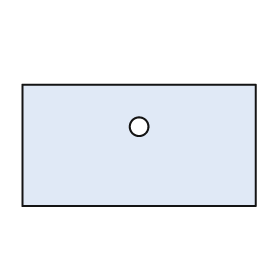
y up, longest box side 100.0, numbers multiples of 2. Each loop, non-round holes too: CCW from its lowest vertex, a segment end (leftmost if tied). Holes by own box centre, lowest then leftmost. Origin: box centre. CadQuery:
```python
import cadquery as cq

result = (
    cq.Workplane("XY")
    .moveTo(-50.0, -26.0)
    .lineTo(50.0, -26.0)
    .lineTo(50.0, 26.0)
    .lineTo(-50.0, 26.0)
    .close()
    .moveTo(0.0, 8.0)
    .circle(4.0)
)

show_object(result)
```